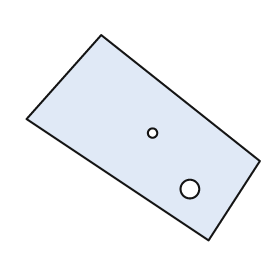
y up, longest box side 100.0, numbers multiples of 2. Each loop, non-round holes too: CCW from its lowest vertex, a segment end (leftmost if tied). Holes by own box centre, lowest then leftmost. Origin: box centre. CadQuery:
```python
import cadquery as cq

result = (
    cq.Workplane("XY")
    .moveTo(28.0, -44.0)
    .lineTo(50.0, -10.0)
    .lineTo(-18.0, 44.0)
    .lineTo(-50.0, 8.0)
    .close()
    .moveTo(20.0, -22.0)
    .circle(4.0)
    .moveTo(4.0, 2.0)
    .circle(2.0)
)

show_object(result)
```